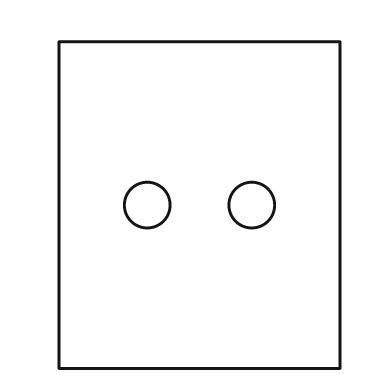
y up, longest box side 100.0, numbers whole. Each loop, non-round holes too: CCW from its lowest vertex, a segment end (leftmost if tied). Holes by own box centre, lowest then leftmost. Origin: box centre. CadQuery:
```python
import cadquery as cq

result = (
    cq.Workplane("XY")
    .moveTo(-43.0, -50.0)
    .lineTo(43.0, -50.0)
    .lineTo(43.0, 50.0)
    .lineTo(-43.0, 50.0)
    .close()
    .moveTo(-16.0, 0.0)
    .circle(7.0)
    .moveTo(16.0, 0.0)
    .circle(7.0)
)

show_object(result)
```